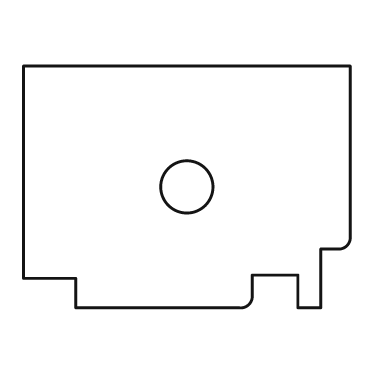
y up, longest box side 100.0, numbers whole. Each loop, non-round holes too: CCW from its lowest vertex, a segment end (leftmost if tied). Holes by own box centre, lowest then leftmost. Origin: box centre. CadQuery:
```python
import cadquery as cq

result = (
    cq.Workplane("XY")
    .moveTo(-34.0, -37.0)
    .lineTo(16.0, -37.0)
    .threePointArc((19.0, -36.0), (20.0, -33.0))
    .lineTo(20.0, -27.0)
    .lineTo(34.0, -27.0)
    .lineTo(34.0, -37.0)
    .lineTo(41.0, -37.0)
    .lineTo(41.0, -19.0)
    .lineTo(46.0, -19.0)
    .threePointArc((49.0, -18.0), (50.0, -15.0))
    .lineTo(50.0, 37.0)
    .lineTo(-50.0, 37.0)
    .lineTo(-50.0, -28.0)
    .lineTo(-34.0, -28.0)
    .close()
    .moveTo(0.0, 0.0)
    .circle(8.0)
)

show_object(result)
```